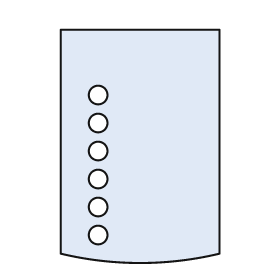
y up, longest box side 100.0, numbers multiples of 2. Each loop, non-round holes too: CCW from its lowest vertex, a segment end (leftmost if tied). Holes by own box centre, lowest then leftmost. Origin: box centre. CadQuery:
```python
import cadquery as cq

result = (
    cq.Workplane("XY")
    .moveTo(-34.0, -46.0)
    .threePointArc((0.0, -50.0), (34.0, -46.0))
    .lineTo(34.0, 50.0)
    .lineTo(-34.0, 50.0)
    .close()
    .moveTo(-18.0, -38.0)
    .circle(4.0)
    .moveTo(-18.0, -26.0)
    .circle(4.0)
    .moveTo(-18.0, -14.0)
    .circle(4.0)
    .moveTo(-18.0, -2.0)
    .circle(4.0)
    .moveTo(-18.0, 10.0)
    .circle(4.0)
    .moveTo(-18.0, 22.0)
    .circle(4.0)
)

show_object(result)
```